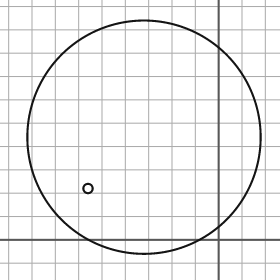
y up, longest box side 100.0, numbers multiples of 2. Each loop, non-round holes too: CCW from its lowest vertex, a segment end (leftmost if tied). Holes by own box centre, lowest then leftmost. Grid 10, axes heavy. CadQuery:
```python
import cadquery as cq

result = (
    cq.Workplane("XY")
    .moveTo(-32.0, 44.0)
    .circle(50.0)
    .moveTo(-56.0, 22.0)
    .circle(2.0)
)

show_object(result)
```